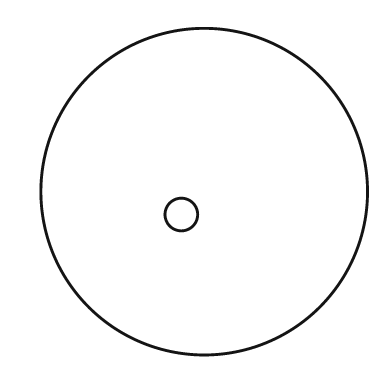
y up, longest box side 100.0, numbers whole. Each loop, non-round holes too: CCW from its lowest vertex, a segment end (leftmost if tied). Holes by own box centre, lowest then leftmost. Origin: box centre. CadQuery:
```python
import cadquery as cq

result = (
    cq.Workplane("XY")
    .moveTo(0.0, 0.0)
    .circle(50.0)
    .moveTo(-7.0, -7.0)
    .circle(5.0)
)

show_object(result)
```